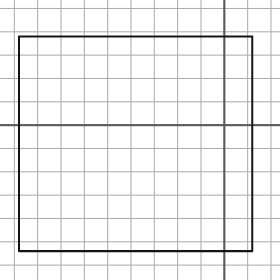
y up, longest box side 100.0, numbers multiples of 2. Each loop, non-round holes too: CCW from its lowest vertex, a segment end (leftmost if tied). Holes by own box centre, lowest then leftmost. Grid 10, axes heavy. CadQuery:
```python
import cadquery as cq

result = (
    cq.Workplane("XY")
    .moveTo(-88.0, -54.0)
    .lineTo(12.0, -54.0)
    .lineTo(12.0, 38.0)
    .lineTo(-88.0, 38.0)
    .close()
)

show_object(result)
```